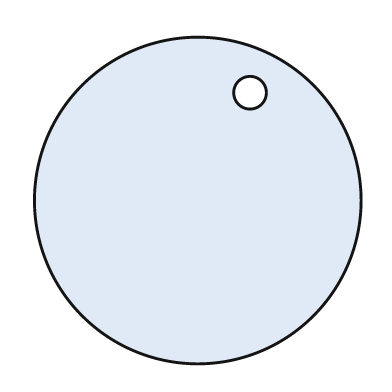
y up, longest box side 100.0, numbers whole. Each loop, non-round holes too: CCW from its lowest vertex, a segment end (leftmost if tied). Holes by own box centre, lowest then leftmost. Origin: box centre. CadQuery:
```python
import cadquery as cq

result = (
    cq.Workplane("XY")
    .moveTo(0.0, 0.0)
    .circle(50.0)
    .moveTo(16.0, 33.0)
    .circle(5.0)
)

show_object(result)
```